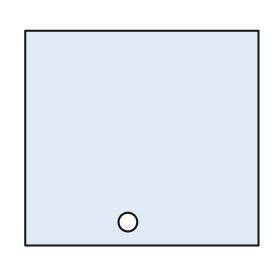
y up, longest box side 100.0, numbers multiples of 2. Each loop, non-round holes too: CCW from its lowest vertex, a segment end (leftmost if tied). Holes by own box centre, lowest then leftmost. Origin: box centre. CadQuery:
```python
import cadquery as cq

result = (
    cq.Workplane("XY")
    .moveTo(-50.0, -46.0)
    .lineTo(50.0, -46.0)
    .lineTo(50.0, 46.0)
    .lineTo(-50.0, 46.0)
    .close()
    .moveTo(-6.0, -36.0)
    .circle(4.0)
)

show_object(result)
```